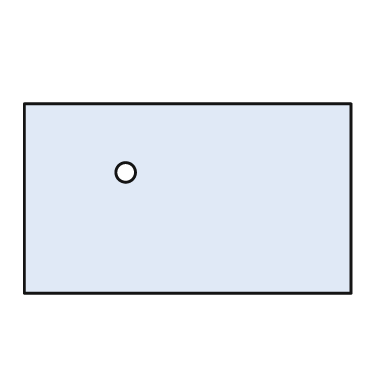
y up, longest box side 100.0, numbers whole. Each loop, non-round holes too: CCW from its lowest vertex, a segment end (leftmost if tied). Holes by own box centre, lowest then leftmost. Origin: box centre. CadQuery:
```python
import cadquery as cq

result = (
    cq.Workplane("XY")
    .moveTo(-50.0, -29.0)
    .lineTo(50.0, -29.0)
    .lineTo(50.0, 29.0)
    .lineTo(-50.0, 29.0)
    .close()
    .moveTo(-19.0, 8.0)
    .circle(3.0)
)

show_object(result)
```